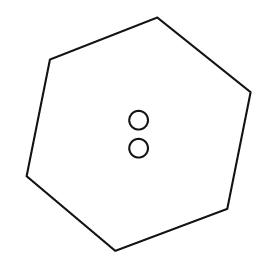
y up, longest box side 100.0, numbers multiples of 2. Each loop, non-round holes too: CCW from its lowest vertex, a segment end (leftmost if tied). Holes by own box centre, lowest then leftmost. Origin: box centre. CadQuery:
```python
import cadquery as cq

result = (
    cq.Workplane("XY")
    .moveTo(-10.0, -50.0)
    .lineTo(38.0, -32.0)
    .lineTo(48.0, 18.0)
    .lineTo(8.0, 50.0)
    .lineTo(-38.0, 32.0)
    .lineTo(-48.0, -18.0)
    .close()
    .moveTo(0.0, -6.0)
    .circle(4.0)
    .moveTo(0.0, 6.0)
    .circle(4.0)
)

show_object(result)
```